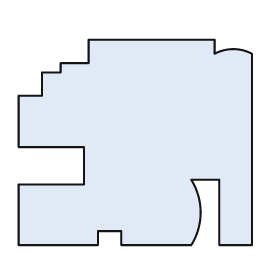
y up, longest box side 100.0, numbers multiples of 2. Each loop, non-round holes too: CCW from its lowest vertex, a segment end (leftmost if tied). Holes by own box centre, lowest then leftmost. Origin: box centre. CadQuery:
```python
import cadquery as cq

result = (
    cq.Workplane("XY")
    .moveTo(-50.0, -44.0)
    .lineTo(-16.0, -44.0)
    .lineTo(-16.0, -38.0)
    .lineTo(-6.0, -38.0)
    .lineTo(-6.0, -44.0)
    .lineTo(24.0, -44.0)
    .threePointArc((28.0, -30.0), (24.0, -16.0))
    .lineTo(36.0, -16.0)
    .lineTo(36.0, -44.0)
    .lineTo(50.0, -44.0)
    .lineTo(50.0, 38.0)
    .threePointArc((42.0, 40.0), (34.0, 38.0))
    .lineTo(34.0, 44.0)
    .lineTo(-20.0, 44.0)
    .lineTo(-20.0, 34.0)
    .lineTo(-32.0, 34.0)
    .lineTo(-32.0, 30.0)
    .lineTo(-40.0, 30.0)
    .lineTo(-40.0, 20.0)
    .lineTo(-50.0, 20.0)
    .lineTo(-50.0, -2.0)
    .lineTo(-22.0, -2.0)
    .lineTo(-22.0, -18.0)
    .lineTo(-50.0, -18.0)
    .close()
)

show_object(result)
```